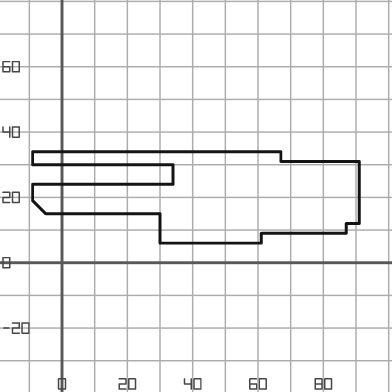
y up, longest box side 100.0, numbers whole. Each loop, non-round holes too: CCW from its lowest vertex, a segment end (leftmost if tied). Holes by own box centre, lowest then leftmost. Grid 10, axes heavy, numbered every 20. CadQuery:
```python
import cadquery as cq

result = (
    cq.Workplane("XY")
    .moveTo(30.0, 6.0)
    .lineTo(61.0, 6.0)
    .lineTo(61.0, 9.0)
    .lineTo(87.0, 9.0)
    .lineTo(87.0, 12.0)
    .lineTo(91.0, 12.0)
    .lineTo(91.0, 31.0)
    .lineTo(67.0, 31.0)
    .lineTo(67.0, 34.0)
    .lineTo(-9.0, 34.0)
    .lineTo(-9.0, 30.0)
    .lineTo(34.0, 30.0)
    .lineTo(34.0, 24.0)
    .lineTo(-9.0, 24.0)
    .lineTo(-9.0, 19.0)
    .lineTo(-5.0, 15.0)
    .lineTo(30.0, 15.0)
    .close()
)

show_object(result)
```